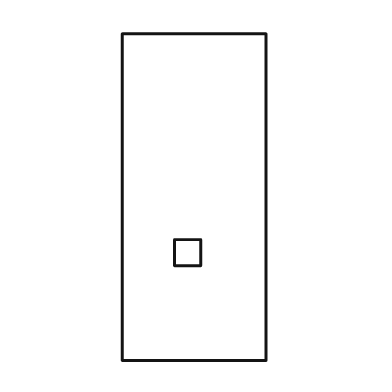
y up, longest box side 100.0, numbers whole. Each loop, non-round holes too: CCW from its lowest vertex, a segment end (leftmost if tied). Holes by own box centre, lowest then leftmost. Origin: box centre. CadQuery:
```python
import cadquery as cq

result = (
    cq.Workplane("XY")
    .moveTo(-22.0, -50.0)
    .lineTo(22.0, -50.0)
    .lineTo(22.0, 50.0)
    .lineTo(-22.0, 50.0)
    .close()
    .moveTo(-6.0, -21.0)
    .lineTo(2.0, -21.0)
    .lineTo(2.0, -13.0)
    .lineTo(-6.0, -13.0)
    .close()
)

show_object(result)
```